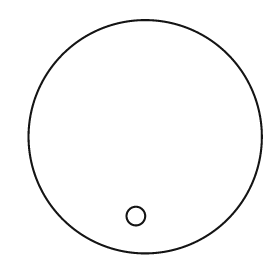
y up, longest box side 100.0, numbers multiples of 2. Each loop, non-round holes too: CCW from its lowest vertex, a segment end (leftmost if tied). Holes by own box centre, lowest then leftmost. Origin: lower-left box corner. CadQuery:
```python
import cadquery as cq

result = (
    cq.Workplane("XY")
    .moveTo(50.0, 50.0)
    .circle(50.0)
    .moveTo(46.0, 16.0)
    .circle(4.0)
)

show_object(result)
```